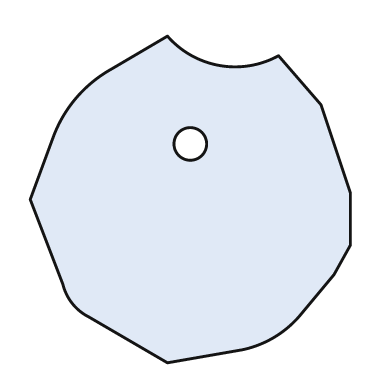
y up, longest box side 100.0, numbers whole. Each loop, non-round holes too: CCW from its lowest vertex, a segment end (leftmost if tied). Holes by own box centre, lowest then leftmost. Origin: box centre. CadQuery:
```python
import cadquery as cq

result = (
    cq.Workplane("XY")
    .moveTo(-7.0, -50.0)
    .lineTo(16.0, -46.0)
    .threePointArc((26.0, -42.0), (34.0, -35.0))
    .lineTo(44.0, -23.0)
    .lineTo(49.0, -14.0)
    .lineTo(49.0, 2.0)
    .lineTo(40.0, 29.0)
    .lineTo(27.0, 44.0)
    .threePointArc((9.0, 41.0), (-7.0, 50.0))
    .lineTo(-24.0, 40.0)
    .threePointArc((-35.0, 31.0), (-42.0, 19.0))
    .lineTo(-49.0, 0.0)
    .lineTo(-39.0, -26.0)
    .threePointArc((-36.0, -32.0), (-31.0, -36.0))
    .close()
    .moveTo(0.0, 17.0)
    .circle(5.0)
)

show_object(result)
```